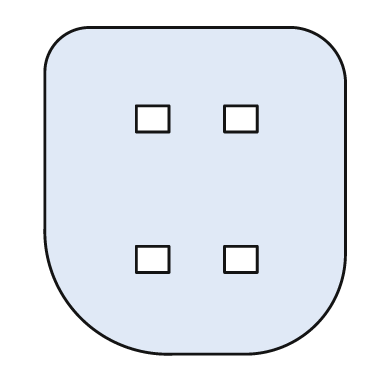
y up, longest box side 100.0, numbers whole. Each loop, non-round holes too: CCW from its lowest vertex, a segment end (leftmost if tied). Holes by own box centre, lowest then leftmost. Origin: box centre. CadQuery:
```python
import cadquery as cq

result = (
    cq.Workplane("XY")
    .moveTo(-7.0, -50.0)
    .lineTo(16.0, -50.0)
    .threePointArc((37.0, -41.0), (46.0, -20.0))
    .lineTo(46.0, 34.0)
    .threePointArc((41.0, 45.0), (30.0, 50.0))
    .lineTo(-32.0, 50.0)
    .threePointArc((-42.0, 46.0), (-46.0, 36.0))
    .lineTo(-46.0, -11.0)
    .threePointArc((-35.0, -39.0), (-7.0, -50.0))
    .close()
    .moveTo(-18.0, -25.0)
    .lineTo(-8.0, -25.0)
    .lineTo(-8.0, -17.0)
    .lineTo(-18.0, -17.0)
    .close()
    .moveTo(9.0, -25.0)
    .lineTo(19.0, -25.0)
    .lineTo(19.0, -17.0)
    .lineTo(9.0, -17.0)
    .close()
    .moveTo(-18.0, 18.0)
    .lineTo(-8.0, 18.0)
    .lineTo(-8.0, 26.0)
    .lineTo(-18.0, 26.0)
    .close()
    .moveTo(9.0, 18.0)
    .lineTo(19.0, 18.0)
    .lineTo(19.0, 26.0)
    .lineTo(9.0, 26.0)
    .close()
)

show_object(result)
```